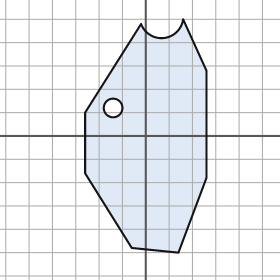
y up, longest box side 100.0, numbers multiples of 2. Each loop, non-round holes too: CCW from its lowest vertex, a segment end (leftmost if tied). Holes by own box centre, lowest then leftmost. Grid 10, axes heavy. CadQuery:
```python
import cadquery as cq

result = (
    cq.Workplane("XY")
    .moveTo(14.0, -50.0)
    .lineTo(26.0, -18.0)
    .lineTo(26.0, 28.0)
    .lineTo(16.0, 50.0)
    .threePointArc((8.0, 42.0), (-2.0, 48.0))
    .lineTo(-26.0, 10.0)
    .lineTo(-26.0, -16.0)
    .lineTo(-6.0, -48.0)
    .close()
    .moveTo(-14.0, 12.0)
    .circle(4.0)
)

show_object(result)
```